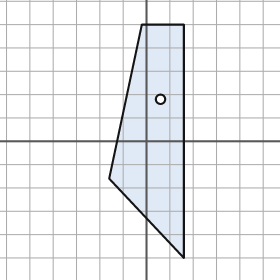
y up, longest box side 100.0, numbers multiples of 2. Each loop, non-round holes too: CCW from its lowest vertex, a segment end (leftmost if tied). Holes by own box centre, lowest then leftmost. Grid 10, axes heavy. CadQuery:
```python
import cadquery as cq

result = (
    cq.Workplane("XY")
    .moveTo(16.0, -50.0)
    .lineTo(16.0, 50.0)
    .lineTo(-2.0, 50.0)
    .lineTo(-16.0, -16.0)
    .close()
    .moveTo(6.0, 18.0)
    .circle(2.0)
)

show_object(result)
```